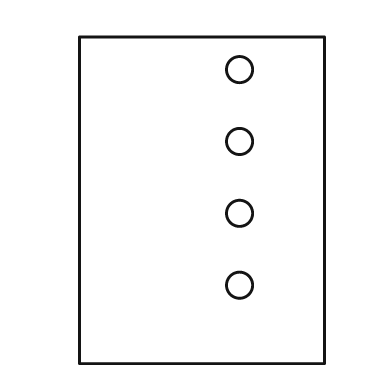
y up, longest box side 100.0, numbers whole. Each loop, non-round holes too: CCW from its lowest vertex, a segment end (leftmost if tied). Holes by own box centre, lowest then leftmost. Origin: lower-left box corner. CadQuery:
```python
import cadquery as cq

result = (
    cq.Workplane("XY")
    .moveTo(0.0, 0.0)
    .lineTo(75.0, 0.0)
    .lineTo(75.0, 100.0)
    .lineTo(0.0, 100.0)
    .close()
    .moveTo(49.0, 24.0)
    .circle(4.0)
    .moveTo(49.0, 46.0)
    .circle(4.0)
    .moveTo(49.0, 68.0)
    .circle(4.0)
    .moveTo(49.0, 90.0)
    .circle(4.0)
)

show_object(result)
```